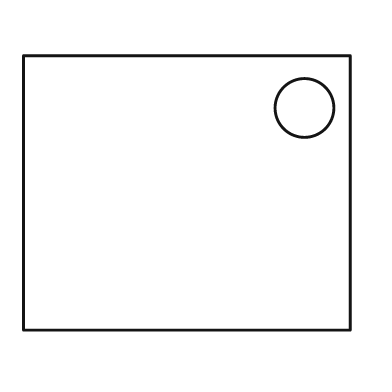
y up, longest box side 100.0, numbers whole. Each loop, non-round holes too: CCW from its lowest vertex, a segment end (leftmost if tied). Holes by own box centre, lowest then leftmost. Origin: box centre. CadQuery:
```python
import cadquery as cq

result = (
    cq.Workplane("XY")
    .moveTo(-50.0, -42.0)
    .lineTo(50.0, -42.0)
    .lineTo(50.0, 42.0)
    .lineTo(-50.0, 42.0)
    .close()
    .moveTo(36.0, 26.0)
    .circle(9.0)
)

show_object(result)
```